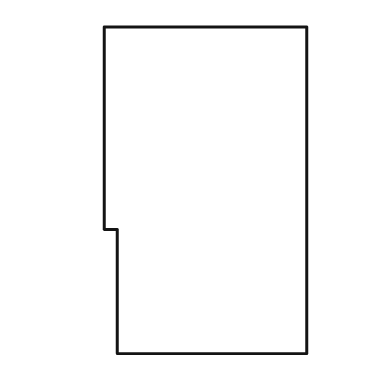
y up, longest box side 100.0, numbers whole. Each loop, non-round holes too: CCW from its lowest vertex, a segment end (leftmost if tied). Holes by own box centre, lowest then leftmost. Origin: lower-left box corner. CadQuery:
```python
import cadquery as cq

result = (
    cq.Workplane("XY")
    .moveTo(4.0, 0.0)
    .lineTo(62.0, 0.0)
    .lineTo(62.0, 100.0)
    .lineTo(0.0, 100.0)
    .lineTo(0.0, 38.0)
    .lineTo(4.0, 38.0)
    .close()
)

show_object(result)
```